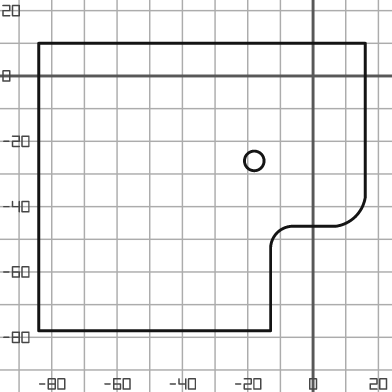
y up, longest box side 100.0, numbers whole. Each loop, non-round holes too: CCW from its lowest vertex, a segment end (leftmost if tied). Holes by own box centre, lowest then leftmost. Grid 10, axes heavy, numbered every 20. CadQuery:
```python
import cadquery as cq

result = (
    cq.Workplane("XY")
    .moveTo(-84.0, -78.0)
    .lineTo(-13.0, -78.0)
    .lineTo(-13.0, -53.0)
    .threePointArc((-11.0, -48.0), (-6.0, -46.0))
    .lineTo(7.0, -46.0)
    .threePointArc((13.0, -43.0), (16.0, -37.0))
    .lineTo(16.0, 10.0)
    .lineTo(-84.0, 10.0)
    .close()
    .moveTo(-18.0, -26.0)
    .circle(3.0)
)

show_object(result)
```